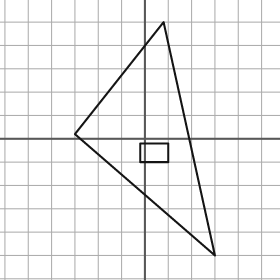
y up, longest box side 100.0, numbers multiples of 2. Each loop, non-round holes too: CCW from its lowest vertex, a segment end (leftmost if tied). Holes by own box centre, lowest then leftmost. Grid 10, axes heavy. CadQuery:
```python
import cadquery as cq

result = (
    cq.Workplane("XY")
    .moveTo(30.0, -50.0)
    .lineTo(8.0, 50.0)
    .lineTo(-30.0, 2.0)
    .close()
    .moveTo(-2.0, -10.0)
    .lineTo(10.0, -10.0)
    .lineTo(10.0, -2.0)
    .lineTo(-2.0, -2.0)
    .close()
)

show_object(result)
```